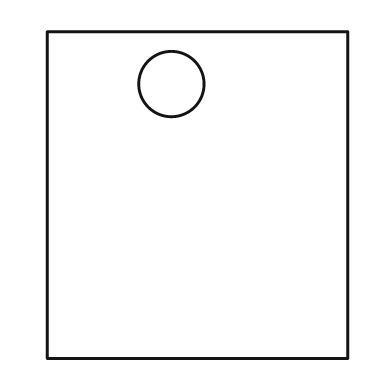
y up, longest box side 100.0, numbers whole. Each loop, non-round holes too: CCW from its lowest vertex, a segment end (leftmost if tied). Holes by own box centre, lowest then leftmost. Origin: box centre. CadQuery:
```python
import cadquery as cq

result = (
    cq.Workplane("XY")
    .moveTo(-46.0, -50.0)
    .lineTo(46.0, -50.0)
    .lineTo(46.0, 50.0)
    .lineTo(-46.0, 50.0)
    .close()
    .moveTo(-8.0, 34.0)
    .circle(10.0)
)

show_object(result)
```